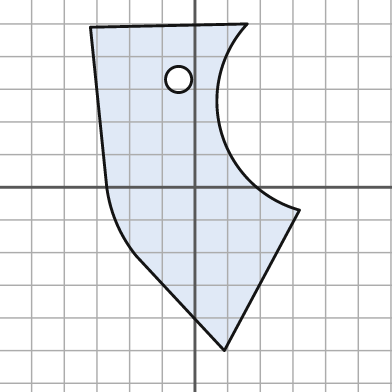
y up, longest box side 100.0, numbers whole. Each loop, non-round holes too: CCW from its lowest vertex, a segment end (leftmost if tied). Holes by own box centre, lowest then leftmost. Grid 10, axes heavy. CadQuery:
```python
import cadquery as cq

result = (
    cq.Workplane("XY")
    .moveTo(9.0, -50.0)
    .lineTo(32.0, -7.0)
    .threePointArc((8.0, 17.0), (16.0, 50.0))
    .lineTo(-32.0, 49.0)
    .lineTo(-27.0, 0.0)
    .threePointArc((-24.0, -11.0), (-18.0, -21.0))
    .close()
    .moveTo(-5.0, 33.0)
    .circle(4.0)
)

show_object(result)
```